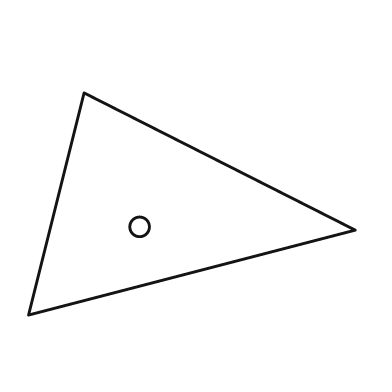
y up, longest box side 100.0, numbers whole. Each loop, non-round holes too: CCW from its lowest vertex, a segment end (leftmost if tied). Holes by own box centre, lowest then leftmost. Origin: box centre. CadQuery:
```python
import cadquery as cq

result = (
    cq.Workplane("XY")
    .moveTo(-50.0, -34.0)
    .lineTo(50.0, -8.0)
    .lineTo(-33.0, 34.0)
    .close()
    .moveTo(-16.0, -7.0)
    .circle(3.0)
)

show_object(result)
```